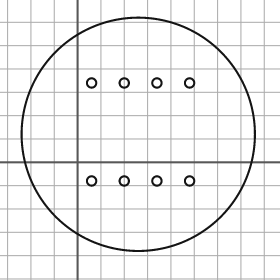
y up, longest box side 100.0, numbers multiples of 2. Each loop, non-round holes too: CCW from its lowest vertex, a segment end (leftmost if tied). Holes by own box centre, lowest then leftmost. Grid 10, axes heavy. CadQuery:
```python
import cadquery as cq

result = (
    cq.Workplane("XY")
    .moveTo(26.0, 12.0)
    .circle(50.0)
    .moveTo(6.0, -8.0)
    .circle(2.0)
    .moveTo(20.0, -8.0)
    .circle(2.0)
    .moveTo(34.0, -8.0)
    .circle(2.0)
    .moveTo(48.0, -8.0)
    .circle(2.0)
    .moveTo(6.0, 34.0)
    .circle(2.0)
    .moveTo(20.0, 34.0)
    .circle(2.0)
    .moveTo(34.0, 34.0)
    .circle(2.0)
    .moveTo(48.0, 34.0)
    .circle(2.0)
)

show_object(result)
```